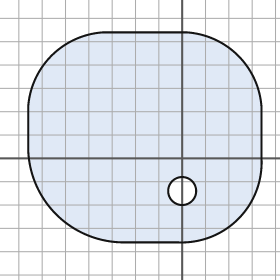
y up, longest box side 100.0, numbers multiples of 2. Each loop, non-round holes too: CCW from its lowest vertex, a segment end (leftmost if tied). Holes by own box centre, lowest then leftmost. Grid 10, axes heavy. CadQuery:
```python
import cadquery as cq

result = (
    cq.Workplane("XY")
    .moveTo(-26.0, -36.0)
    .lineTo(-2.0, -36.0)
    .threePointArc((24.0, -26.0), (34.0, 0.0))
    .lineTo(34.0, 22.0)
    .threePointArc((24.0, 44.0), (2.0, 54.0))
    .lineTo(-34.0, 54.0)
    .threePointArc((-56.0, 44.0), (-66.0, 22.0))
    .lineTo(-66.0, 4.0)
    .threePointArc((-54.0, -24.0), (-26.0, -36.0))
    .close()
    .moveTo(0.0, -14.0)
    .circle(6.0)
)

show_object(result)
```